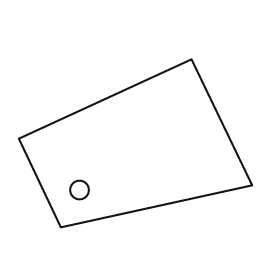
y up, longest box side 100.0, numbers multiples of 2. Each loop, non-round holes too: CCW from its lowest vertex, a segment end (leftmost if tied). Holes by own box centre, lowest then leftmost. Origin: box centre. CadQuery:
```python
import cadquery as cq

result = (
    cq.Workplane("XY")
    .moveTo(-32.0, -36.0)
    .lineTo(50.0, -18.0)
    .lineTo(24.0, 36.0)
    .lineTo(-50.0, 2.0)
    .close()
    .moveTo(-24.0, -20.0)
    .circle(4.0)
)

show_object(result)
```